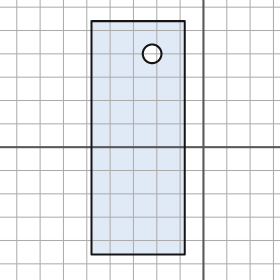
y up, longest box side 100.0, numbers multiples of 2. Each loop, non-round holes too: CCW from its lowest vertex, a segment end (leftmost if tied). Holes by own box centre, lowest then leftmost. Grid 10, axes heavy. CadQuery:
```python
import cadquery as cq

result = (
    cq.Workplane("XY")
    .moveTo(-48.0, -46.0)
    .lineTo(-8.0, -46.0)
    .lineTo(-8.0, 54.0)
    .lineTo(-48.0, 54.0)
    .close()
    .moveTo(-22.0, 40.0)
    .circle(4.0)
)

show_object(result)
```